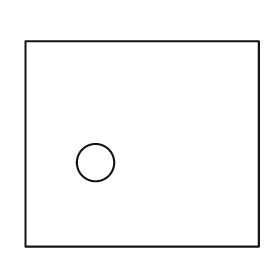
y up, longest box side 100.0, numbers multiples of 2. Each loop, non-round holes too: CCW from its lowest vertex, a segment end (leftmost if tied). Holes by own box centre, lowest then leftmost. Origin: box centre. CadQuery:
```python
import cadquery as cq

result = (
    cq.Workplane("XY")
    .moveTo(-50.0, -44.0)
    .lineTo(50.0, -44.0)
    .lineTo(50.0, 44.0)
    .lineTo(-50.0, 44.0)
    .close()
    .moveTo(-20.0, -8.0)
    .circle(8.0)
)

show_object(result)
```